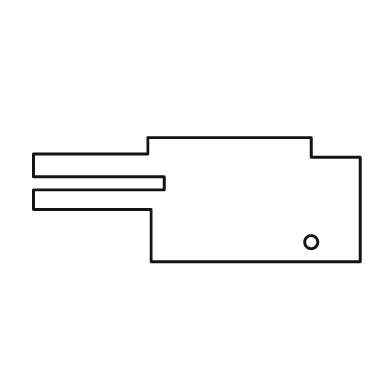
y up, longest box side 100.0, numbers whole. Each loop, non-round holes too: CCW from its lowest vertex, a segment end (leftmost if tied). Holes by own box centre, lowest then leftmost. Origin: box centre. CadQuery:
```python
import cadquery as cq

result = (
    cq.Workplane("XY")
    .moveTo(-14.0, -19.0)
    .lineTo(50.0, -19.0)
    .lineTo(50.0, 13.0)
    .lineTo(35.0, 13.0)
    .lineTo(35.0, 19.0)
    .lineTo(-15.0, 19.0)
    .lineTo(-15.0, 14.0)
    .lineTo(-50.0, 14.0)
    .lineTo(-50.0, 7.0)
    .lineTo(-10.0, 7.0)
    .lineTo(-10.0, 3.0)
    .lineTo(-50.0, 3.0)
    .lineTo(-50.0, -3.0)
    .lineTo(-14.0, -3.0)
    .close()
    .moveTo(35.0, -13.0)
    .circle(2.0)
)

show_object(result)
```